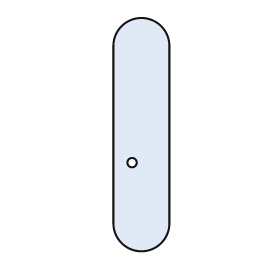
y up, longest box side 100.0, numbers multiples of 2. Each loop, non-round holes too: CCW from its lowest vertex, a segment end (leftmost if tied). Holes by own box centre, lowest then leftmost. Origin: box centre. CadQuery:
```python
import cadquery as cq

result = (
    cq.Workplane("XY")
    .moveTo(-12.0, -38.0)
    .threePointArc((0.0, -50.0), (12.0, -38.0))
    .lineTo(12.0, 38.0)
    .threePointArc((0.0, 50.0), (-12.0, 38.0))
    .close()
    .moveTo(-4.0, -12.0)
    .circle(2.0)
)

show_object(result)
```